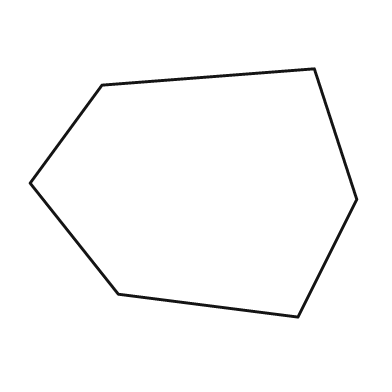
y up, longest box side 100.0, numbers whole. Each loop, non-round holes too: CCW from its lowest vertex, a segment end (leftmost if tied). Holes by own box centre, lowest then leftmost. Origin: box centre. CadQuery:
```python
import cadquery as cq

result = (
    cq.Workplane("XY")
    .moveTo(32.0, -38.0)
    .lineTo(50.0, -2.0)
    .lineTo(37.0, 38.0)
    .lineTo(-28.0, 33.0)
    .lineTo(-50.0, 3.0)
    .lineTo(-23.0, -31.0)
    .close()
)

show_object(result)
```